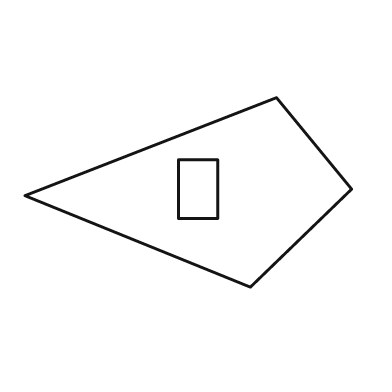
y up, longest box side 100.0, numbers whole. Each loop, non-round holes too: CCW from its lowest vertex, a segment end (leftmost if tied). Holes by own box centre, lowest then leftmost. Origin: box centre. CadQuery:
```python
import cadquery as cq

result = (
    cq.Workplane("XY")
    .moveTo(19.0, -29.0)
    .lineTo(50.0, 1.0)
    .lineTo(27.0, 29.0)
    .lineTo(-50.0, -1.0)
    .close()
    .moveTo(-3.0, -8.0)
    .lineTo(9.0, -8.0)
    .lineTo(9.0, 10.0)
    .lineTo(-3.0, 10.0)
    .close()
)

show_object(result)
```